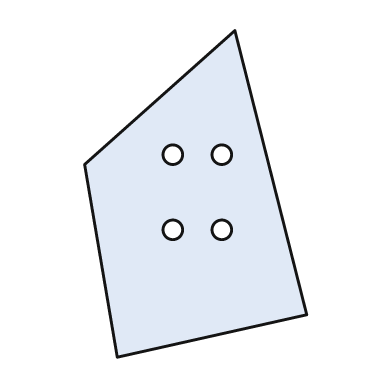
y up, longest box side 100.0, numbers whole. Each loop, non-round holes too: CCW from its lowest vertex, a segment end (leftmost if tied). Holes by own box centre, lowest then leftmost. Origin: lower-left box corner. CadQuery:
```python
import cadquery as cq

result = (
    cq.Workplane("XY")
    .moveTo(10.0, 0.0)
    .lineTo(68.0, 13.0)
    .lineTo(46.0, 100.0)
    .lineTo(0.0, 59.0)
    .close()
    .moveTo(27.0, 39.0)
    .circle(3.0)
    .moveTo(42.0, 39.0)
    .circle(3.0)
    .moveTo(27.0, 62.0)
    .circle(3.0)
    .moveTo(42.0, 62.0)
    .circle(3.0)
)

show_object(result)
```